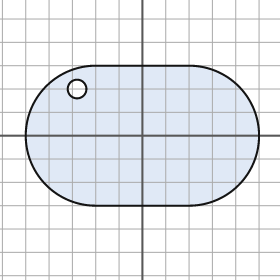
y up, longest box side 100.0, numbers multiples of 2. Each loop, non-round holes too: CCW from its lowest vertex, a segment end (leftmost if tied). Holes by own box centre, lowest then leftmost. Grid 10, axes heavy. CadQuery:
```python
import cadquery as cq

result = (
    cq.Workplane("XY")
    .moveTo(-20.0, -30.0)
    .lineTo(20.0, -30.0)
    .threePointArc((50.0, 0.0), (20.0, 30.0))
    .lineTo(-20.0, 30.0)
    .threePointArc((-50.0, 0.0), (-20.0, -30.0))
    .close()
    .moveTo(-28.0, 20.0)
    .circle(4.0)
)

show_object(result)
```